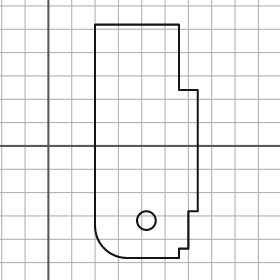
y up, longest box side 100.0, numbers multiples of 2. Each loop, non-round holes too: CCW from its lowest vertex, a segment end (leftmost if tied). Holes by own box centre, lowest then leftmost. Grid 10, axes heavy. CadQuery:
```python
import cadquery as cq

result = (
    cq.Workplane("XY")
    .moveTo(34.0, -48.0)
    .lineTo(56.0, -48.0)
    .lineTo(56.0, -44.0)
    .lineTo(60.0, -44.0)
    .lineTo(60.0, -28.0)
    .lineTo(64.0, -28.0)
    .lineTo(64.0, 24.0)
    .lineTo(56.0, 24.0)
    .lineTo(56.0, 52.0)
    .lineTo(20.0, 52.0)
    .lineTo(20.0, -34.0)
    .threePointArc((24.0, -44.0), (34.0, -48.0))
    .close()
    .moveTo(42.0, -32.0)
    .circle(4.0)
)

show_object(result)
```